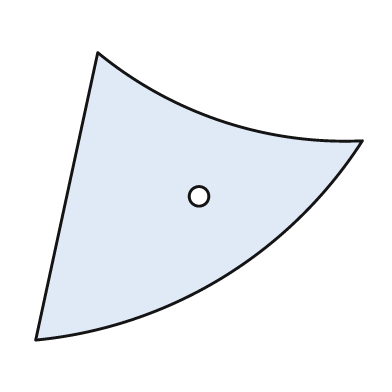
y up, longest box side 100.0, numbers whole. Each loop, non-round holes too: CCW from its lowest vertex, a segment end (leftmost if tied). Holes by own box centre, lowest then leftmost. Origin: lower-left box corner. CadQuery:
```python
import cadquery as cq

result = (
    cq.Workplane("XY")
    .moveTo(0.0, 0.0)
    .threePointArc((57.0, 19.0), (100.0, 61.0))
    .threePointArc((57.0, 67.0), (19.0, 88.0))
    .close()
    .moveTo(50.0, 44.0)
    .circle(3.0)
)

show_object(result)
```